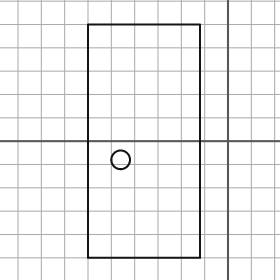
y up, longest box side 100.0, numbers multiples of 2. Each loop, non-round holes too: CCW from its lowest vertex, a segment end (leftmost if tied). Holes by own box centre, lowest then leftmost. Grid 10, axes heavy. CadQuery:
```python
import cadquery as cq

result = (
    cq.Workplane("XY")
    .moveTo(-60.0, -50.0)
    .lineTo(-12.0, -50.0)
    .lineTo(-12.0, 50.0)
    .lineTo(-60.0, 50.0)
    .close()
    .moveTo(-46.0, -8.0)
    .circle(4.0)
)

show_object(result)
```